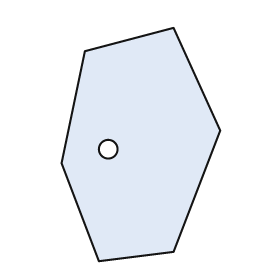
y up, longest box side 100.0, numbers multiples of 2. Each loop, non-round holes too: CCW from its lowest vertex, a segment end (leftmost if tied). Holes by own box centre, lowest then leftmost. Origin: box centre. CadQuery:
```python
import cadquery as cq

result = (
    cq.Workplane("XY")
    .moveTo(-18.0, -50.0)
    .lineTo(14.0, -46.0)
    .lineTo(34.0, 6.0)
    .lineTo(14.0, 50.0)
    .lineTo(-24.0, 40.0)
    .lineTo(-34.0, -8.0)
    .close()
    .moveTo(-14.0, -2.0)
    .circle(4.0)
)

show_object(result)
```